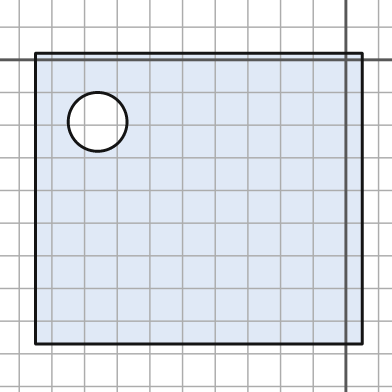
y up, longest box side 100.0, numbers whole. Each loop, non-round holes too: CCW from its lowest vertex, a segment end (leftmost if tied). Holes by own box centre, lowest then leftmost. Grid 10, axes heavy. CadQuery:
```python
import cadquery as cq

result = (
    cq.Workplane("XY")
    .moveTo(-95.0, -87.0)
    .lineTo(5.0, -87.0)
    .lineTo(5.0, 2.0)
    .lineTo(-95.0, 2.0)
    .close()
    .moveTo(-76.0, -19.0)
    .circle(9.0)
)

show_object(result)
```